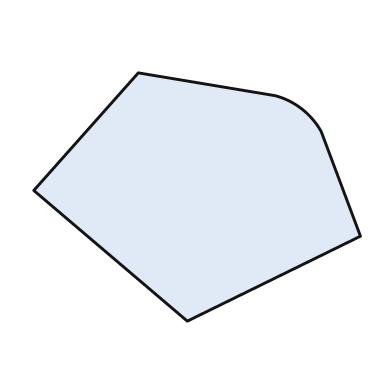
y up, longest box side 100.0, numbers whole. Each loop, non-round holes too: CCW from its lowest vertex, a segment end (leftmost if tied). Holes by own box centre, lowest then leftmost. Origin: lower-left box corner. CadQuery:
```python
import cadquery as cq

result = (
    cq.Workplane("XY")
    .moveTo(47.0, 0.0)
    .lineTo(100.0, 26.0)
    .lineTo(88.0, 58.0)
    .threePointArc((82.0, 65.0), (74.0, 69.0))
    .lineTo(32.0, 76.0)
    .lineTo(0.0, 40.0)
    .close()
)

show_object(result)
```